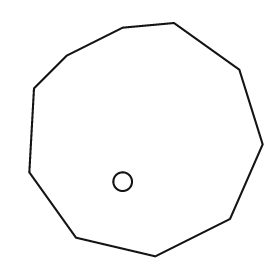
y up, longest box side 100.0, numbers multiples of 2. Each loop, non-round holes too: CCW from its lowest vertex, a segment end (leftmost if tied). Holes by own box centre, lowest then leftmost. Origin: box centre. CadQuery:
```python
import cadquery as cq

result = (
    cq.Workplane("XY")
    .moveTo(4.0, -50.0)
    .lineTo(36.0, -34.0)
    .lineTo(50.0, -2.0)
    .lineTo(40.0, 30.0)
    .lineTo(12.0, 50.0)
    .lineTo(-10.0, 48.0)
    .lineTo(-34.0, 36.0)
    .lineTo(-48.0, 22.0)
    .lineTo(-50.0, -14.0)
    .lineTo(-30.0, -42.0)
    .close()
    .moveTo(-10.0, -18.0)
    .circle(4.0)
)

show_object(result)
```